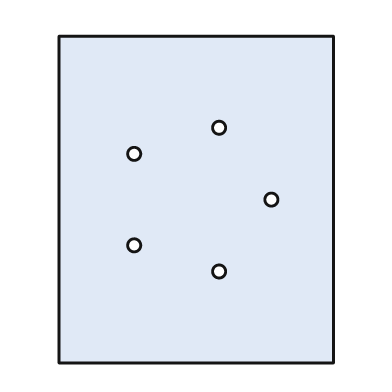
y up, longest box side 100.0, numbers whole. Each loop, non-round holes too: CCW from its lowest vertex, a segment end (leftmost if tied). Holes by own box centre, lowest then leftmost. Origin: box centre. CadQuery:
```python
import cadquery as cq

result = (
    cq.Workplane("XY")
    .moveTo(-42.0, -50.0)
    .lineTo(42.0, -50.0)
    .lineTo(42.0, 50.0)
    .lineTo(-42.0, 50.0)
    .close()
    .moveTo(7.0, -22.0)
    .circle(2.0)
    .moveTo(-19.0, -14.0)
    .circle(2.0)
    .moveTo(23.0, 0.0)
    .circle(2.0)
    .moveTo(-19.0, 14.0)
    .circle(2.0)
    .moveTo(7.0, 22.0)
    .circle(2.0)
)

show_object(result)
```